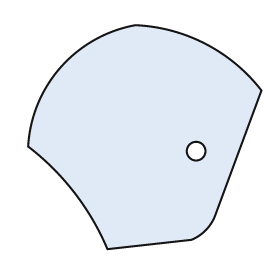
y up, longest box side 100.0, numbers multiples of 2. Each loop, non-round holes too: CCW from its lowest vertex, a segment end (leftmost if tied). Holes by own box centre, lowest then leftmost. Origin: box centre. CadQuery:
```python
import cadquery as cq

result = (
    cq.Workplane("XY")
    .moveTo(-16.0, -48.0)
    .lineTo(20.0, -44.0)
    .threePointArc((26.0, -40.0), (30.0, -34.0))
    .lineTo(50.0, 20.0)
    .threePointArc((26.0, 40.0), (-4.0, 48.0))
    .threePointArc((-36.0, 30.0), (-50.0, -4.0))
    .threePointArc((-30.0, -24.0), (-16.0, -48.0))
    .close()
    .moveTo(22.0, -6.0)
    .circle(4.0)
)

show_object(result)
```